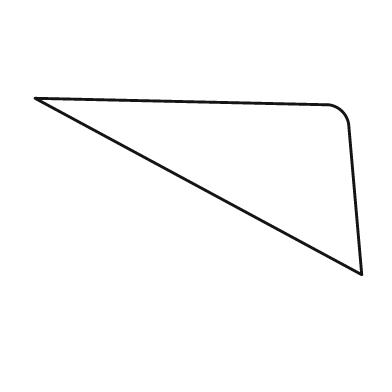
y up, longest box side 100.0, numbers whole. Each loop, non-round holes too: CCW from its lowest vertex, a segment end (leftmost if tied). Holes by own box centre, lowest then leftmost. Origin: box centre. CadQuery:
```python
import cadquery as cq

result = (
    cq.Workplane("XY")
    .moveTo(50.0, -27.0)
    .lineTo(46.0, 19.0)
    .threePointArc((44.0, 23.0), (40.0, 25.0))
    .lineTo(-50.0, 27.0)
    .close()
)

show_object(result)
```